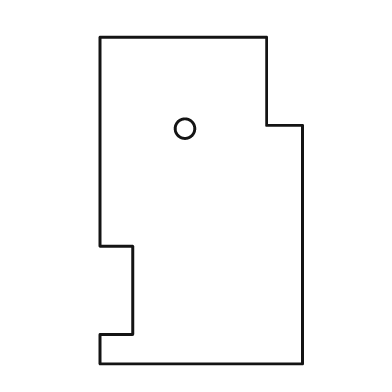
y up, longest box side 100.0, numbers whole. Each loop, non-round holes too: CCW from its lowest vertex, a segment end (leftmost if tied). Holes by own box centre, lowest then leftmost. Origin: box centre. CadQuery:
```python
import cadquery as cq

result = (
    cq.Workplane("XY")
    .moveTo(-31.0, -50.0)
    .lineTo(31.0, -50.0)
    .lineTo(31.0, 23.0)
    .lineTo(20.0, 23.0)
    .lineTo(20.0, 50.0)
    .lineTo(-31.0, 50.0)
    .lineTo(-31.0, -14.0)
    .lineTo(-21.0, -14.0)
    .lineTo(-21.0, -41.0)
    .lineTo(-31.0, -41.0)
    .close()
    .moveTo(-5.0, 22.0)
    .circle(3.0)
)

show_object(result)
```